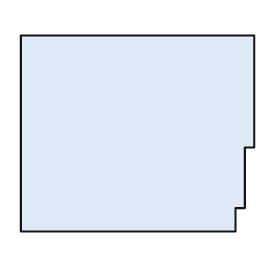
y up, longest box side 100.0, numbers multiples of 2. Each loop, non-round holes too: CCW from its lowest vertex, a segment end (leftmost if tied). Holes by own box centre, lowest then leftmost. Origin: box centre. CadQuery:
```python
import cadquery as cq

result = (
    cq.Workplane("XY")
    .moveTo(-50.0, -42.0)
    .lineTo(42.0, -42.0)
    .lineTo(42.0, -32.0)
    .lineTo(46.0, -32.0)
    .lineTo(46.0, -6.0)
    .lineTo(50.0, -6.0)
    .lineTo(50.0, 42.0)
    .lineTo(-50.0, 42.0)
    .close()
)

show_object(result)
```